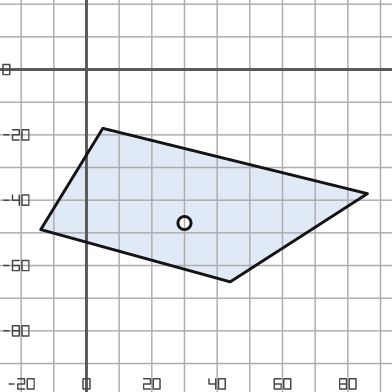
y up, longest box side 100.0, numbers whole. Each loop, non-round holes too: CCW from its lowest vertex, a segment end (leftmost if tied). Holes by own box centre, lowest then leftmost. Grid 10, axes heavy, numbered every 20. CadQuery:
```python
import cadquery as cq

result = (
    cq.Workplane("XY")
    .moveTo(44.0, -65.0)
    .lineTo(86.0, -38.0)
    .lineTo(5.0, -18.0)
    .lineTo(-14.0, -49.0)
    .close()
    .moveTo(30.0, -47.0)
    .circle(2.0)
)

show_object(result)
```